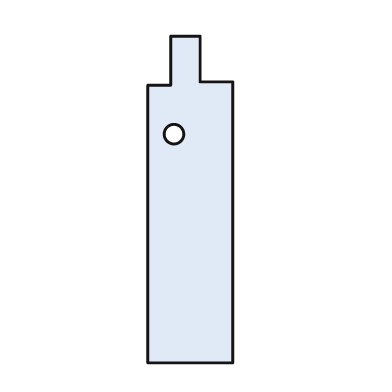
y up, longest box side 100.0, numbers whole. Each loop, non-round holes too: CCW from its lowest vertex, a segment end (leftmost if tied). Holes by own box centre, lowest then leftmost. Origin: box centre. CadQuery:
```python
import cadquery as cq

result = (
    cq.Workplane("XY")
    .moveTo(-13.0, -50.0)
    .lineTo(13.0, -50.0)
    .lineTo(13.0, 36.0)
    .lineTo(3.0, 36.0)
    .lineTo(3.0, 50.0)
    .lineTo(-6.0, 50.0)
    .lineTo(-6.0, 35.0)
    .lineTo(-13.0, 35.0)
    .close()
    .moveTo(-5.0, 20.0)
    .circle(3.0)
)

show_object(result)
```